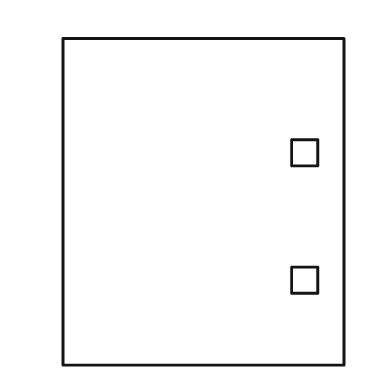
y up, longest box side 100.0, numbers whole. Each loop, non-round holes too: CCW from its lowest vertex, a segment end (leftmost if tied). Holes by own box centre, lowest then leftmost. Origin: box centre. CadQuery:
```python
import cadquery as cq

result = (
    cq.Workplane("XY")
    .moveTo(-43.0, -50.0)
    .lineTo(43.0, -50.0)
    .lineTo(43.0, 50.0)
    .lineTo(-43.0, 50.0)
    .close()
    .moveTo(27.0, -28.0)
    .lineTo(35.0, -28.0)
    .lineTo(35.0, -20.0)
    .lineTo(27.0, -20.0)
    .close()
    .moveTo(27.0, 11.0)
    .lineTo(35.0, 11.0)
    .lineTo(35.0, 19.0)
    .lineTo(27.0, 19.0)
    .close()
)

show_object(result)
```